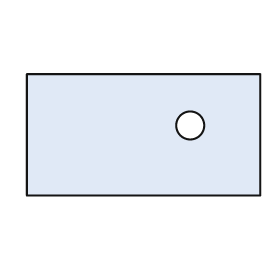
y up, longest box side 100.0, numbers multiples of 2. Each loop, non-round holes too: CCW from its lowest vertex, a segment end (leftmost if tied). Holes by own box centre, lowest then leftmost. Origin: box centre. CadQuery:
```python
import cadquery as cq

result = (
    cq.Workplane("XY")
    .moveTo(-50.0, -26.0)
    .lineTo(50.0, -26.0)
    .lineTo(50.0, 26.0)
    .lineTo(-50.0, 26.0)
    .close()
    .moveTo(20.0, 4.0)
    .circle(6.0)
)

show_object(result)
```